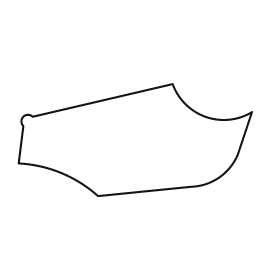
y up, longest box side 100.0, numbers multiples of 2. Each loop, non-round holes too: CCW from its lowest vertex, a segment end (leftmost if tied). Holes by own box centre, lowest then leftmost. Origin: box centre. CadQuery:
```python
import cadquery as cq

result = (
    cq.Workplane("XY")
    .moveTo(-16.0, -24.0)
    .lineTo(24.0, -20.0)
    .threePointArc((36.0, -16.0), (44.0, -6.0))
    .lineTo(50.0, 12.0)
    .threePointArc((30.0, 10.0), (16.0, 24.0))
    .lineTo(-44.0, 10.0)
    .threePointArc((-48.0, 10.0), (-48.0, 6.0))
    .lineTo(-50.0, -10.0)
    .threePointArc((-32.0, -14.0), (-16.0, -24.0))
    .close()
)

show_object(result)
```